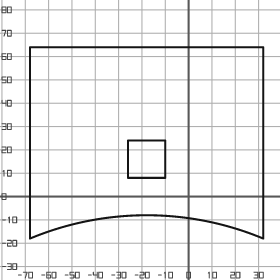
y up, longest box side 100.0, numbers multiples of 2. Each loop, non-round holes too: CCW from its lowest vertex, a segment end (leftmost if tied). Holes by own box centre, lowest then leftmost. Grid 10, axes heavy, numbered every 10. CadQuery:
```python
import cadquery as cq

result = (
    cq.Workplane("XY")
    .moveTo(-68.0, -18.0)
    .threePointArc((-18.0, -8.0), (32.0, -18.0))
    .lineTo(32.0, 64.0)
    .lineTo(-68.0, 64.0)
    .close()
    .moveTo(-26.0, 8.0)
    .lineTo(-10.0, 8.0)
    .lineTo(-10.0, 24.0)
    .lineTo(-26.0, 24.0)
    .close()
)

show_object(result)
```